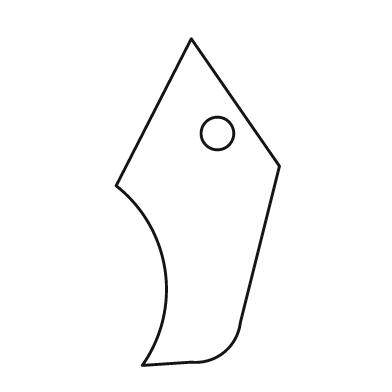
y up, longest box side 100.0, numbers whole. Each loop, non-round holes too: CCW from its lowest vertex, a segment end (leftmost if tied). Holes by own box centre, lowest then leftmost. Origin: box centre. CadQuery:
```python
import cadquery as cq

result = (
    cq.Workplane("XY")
    .moveTo(-17.0, -50.0)
    .lineTo(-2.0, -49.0)
    .threePointArc((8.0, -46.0), (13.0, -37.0))
    .lineTo(25.0, 11.0)
    .lineTo(-2.0, 50.0)
    .lineTo(-25.0, 5.0)
    .threePointArc((-10.0, -21.0), (-17.0, -50.0))
    .close()
    .moveTo(6.0, 21.0)
    .circle(5.0)
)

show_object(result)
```